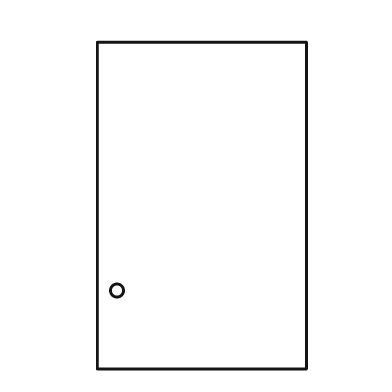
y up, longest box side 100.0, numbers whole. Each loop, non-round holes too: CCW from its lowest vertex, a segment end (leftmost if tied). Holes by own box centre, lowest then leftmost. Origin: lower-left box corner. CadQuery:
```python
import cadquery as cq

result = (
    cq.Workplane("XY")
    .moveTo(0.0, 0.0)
    .lineTo(64.0, 0.0)
    .lineTo(64.0, 100.0)
    .lineTo(0.0, 100.0)
    .close()
    .moveTo(6.0, 24.0)
    .circle(2.0)
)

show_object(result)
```